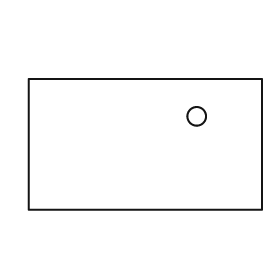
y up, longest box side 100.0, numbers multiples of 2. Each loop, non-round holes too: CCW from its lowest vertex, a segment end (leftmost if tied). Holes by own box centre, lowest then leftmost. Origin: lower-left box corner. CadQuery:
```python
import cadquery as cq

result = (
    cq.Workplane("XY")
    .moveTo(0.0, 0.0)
    .lineTo(100.0, 0.0)
    .lineTo(100.0, 56.0)
    .lineTo(0.0, 56.0)
    .close()
    .moveTo(72.0, 40.0)
    .circle(4.0)
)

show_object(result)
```